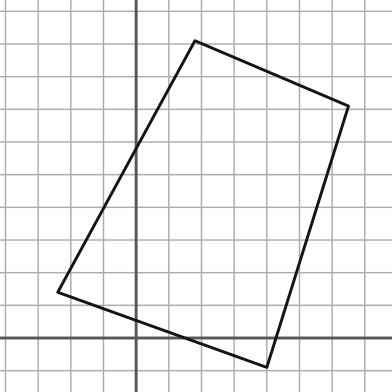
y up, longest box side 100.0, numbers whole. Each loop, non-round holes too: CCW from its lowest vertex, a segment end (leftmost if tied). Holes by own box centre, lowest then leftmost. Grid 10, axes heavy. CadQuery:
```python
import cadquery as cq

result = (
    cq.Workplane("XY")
    .moveTo(40.0, -9.0)
    .lineTo(65.0, 71.0)
    .lineTo(18.0, 91.0)
    .lineTo(-24.0, 14.0)
    .close()
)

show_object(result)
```